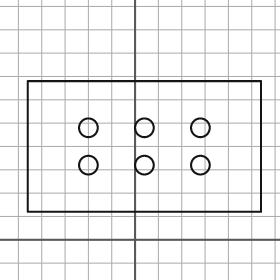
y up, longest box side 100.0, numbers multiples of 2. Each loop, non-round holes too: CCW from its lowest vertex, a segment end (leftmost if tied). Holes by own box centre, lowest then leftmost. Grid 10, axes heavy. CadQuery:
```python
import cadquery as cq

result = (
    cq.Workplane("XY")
    .moveTo(-46.0, 12.0)
    .lineTo(54.0, 12.0)
    .lineTo(54.0, 68.0)
    .lineTo(-46.0, 68.0)
    .close()
    .moveTo(-20.0, 32.0)
    .circle(4.0)
    .moveTo(4.0, 32.0)
    .circle(4.0)
    .moveTo(28.0, 32.0)
    .circle(4.0)
    .moveTo(-20.0, 48.0)
    .circle(4.0)
    .moveTo(4.0, 48.0)
    .circle(4.0)
    .moveTo(28.0, 48.0)
    .circle(4.0)
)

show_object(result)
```